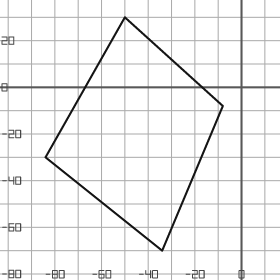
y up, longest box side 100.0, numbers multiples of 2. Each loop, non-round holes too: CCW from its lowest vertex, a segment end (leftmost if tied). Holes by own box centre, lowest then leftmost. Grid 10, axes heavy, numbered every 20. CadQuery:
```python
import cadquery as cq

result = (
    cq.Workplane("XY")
    .moveTo(-34.0, -70.0)
    .lineTo(-8.0, -8.0)
    .lineTo(-50.0, 30.0)
    .lineTo(-84.0, -30.0)
    .close()
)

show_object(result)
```